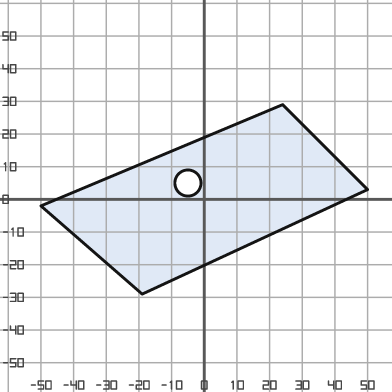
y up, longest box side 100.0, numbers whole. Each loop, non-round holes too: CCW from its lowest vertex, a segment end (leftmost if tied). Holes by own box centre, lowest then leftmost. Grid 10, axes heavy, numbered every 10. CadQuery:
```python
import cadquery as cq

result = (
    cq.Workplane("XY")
    .moveTo(-19.0, -29.0)
    .lineTo(50.0, 3.0)
    .lineTo(24.0, 29.0)
    .lineTo(-50.0, -2.0)
    .close()
    .moveTo(-5.0, 5.0)
    .circle(4.0)
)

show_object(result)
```